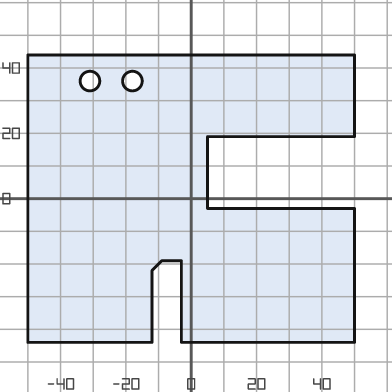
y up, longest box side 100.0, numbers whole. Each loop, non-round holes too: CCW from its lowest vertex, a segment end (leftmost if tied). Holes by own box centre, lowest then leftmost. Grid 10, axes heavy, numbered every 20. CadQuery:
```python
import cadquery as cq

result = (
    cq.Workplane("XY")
    .moveTo(-50.0, -44.0)
    .lineTo(-12.0, -44.0)
    .lineTo(-12.0, -22.0)
    .lineTo(-9.0, -19.0)
    .lineTo(-3.0, -19.0)
    .lineTo(-3.0, -44.0)
    .lineTo(50.0, -44.0)
    .lineTo(50.0, -3.0)
    .lineTo(5.0, -3.0)
    .lineTo(5.0, 19.0)
    .lineTo(50.0, 19.0)
    .lineTo(50.0, 44.0)
    .lineTo(-50.0, 44.0)
    .close()
    .moveTo(-31.0, 36.0)
    .circle(3.0)
    .moveTo(-18.0, 36.0)
    .circle(3.0)
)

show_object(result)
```